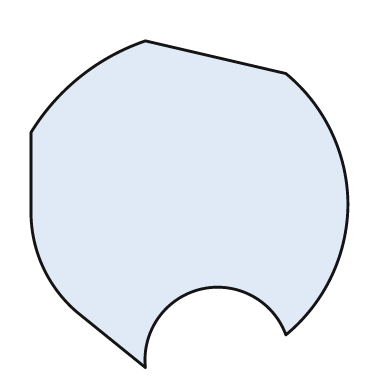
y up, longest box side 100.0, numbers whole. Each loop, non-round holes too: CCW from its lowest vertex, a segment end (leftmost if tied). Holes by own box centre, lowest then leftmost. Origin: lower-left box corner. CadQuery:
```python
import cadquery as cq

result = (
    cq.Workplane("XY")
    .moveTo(35.0, 0.0)
    .threePointArc((52.0, 24.0), (78.0, 10.0))
    .threePointArc((92.0, 28.0), (97.0, 50.0))
    .threePointArc((92.0, 72.0), (78.0, 90.0))
    .lineTo(35.0, 100.0)
    .threePointArc((15.0, 89.0), (0.0, 72.0))
    .lineTo(0.0, 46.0)
    .threePointArc((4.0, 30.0), (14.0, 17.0))
    .close()
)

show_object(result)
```